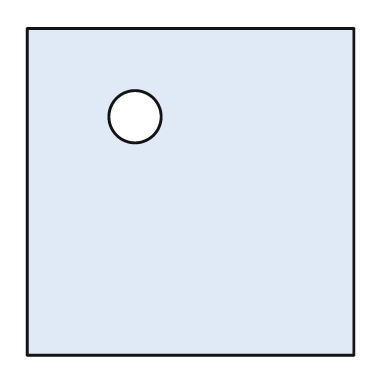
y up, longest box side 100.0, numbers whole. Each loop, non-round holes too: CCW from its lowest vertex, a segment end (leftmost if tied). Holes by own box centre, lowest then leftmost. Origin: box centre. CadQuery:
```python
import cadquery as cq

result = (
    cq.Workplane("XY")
    .moveTo(-50.0, -50.0)
    .lineTo(50.0, -50.0)
    .lineTo(50.0, 50.0)
    .lineTo(-50.0, 50.0)
    .close()
    .moveTo(-17.0, 23.0)
    .circle(8.0)
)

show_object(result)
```